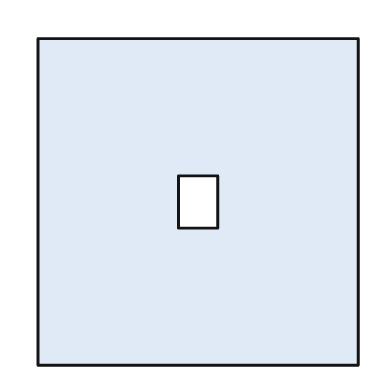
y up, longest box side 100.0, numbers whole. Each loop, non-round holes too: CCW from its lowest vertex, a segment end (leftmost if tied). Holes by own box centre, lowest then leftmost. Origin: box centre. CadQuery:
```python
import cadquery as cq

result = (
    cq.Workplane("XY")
    .moveTo(-49.0, -50.0)
    .lineTo(49.0, -50.0)
    .lineTo(49.0, 50.0)
    .lineTo(-49.0, 50.0)
    .close()
    .moveTo(-6.0, -8.0)
    .lineTo(6.0, -8.0)
    .lineTo(6.0, 8.0)
    .lineTo(-6.0, 8.0)
    .close()
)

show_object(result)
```